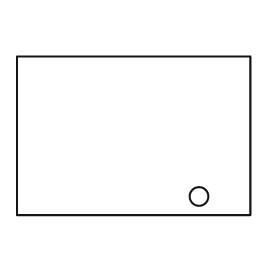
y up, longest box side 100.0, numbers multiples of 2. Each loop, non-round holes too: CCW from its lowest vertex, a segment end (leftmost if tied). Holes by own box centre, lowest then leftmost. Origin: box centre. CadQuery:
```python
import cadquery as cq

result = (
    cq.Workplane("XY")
    .moveTo(-50.0, -34.0)
    .lineTo(50.0, -34.0)
    .lineTo(50.0, 34.0)
    .lineTo(-50.0, 34.0)
    .close()
    .moveTo(28.0, -26.0)
    .circle(4.0)
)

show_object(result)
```